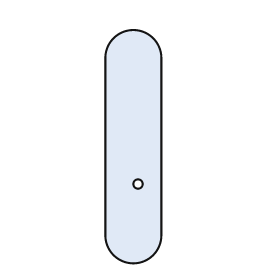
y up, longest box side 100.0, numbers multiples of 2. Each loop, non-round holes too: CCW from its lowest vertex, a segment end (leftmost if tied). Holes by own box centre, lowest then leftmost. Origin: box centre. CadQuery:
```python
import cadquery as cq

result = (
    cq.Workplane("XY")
    .moveTo(-12.0, -38.0)
    .threePointArc((0.0, -50.0), (12.0, -38.0))
    .lineTo(12.0, 38.0)
    .threePointArc((0.0, 50.0), (-12.0, 38.0))
    .close()
    .moveTo(2.0, -16.0)
    .circle(2.0)
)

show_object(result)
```